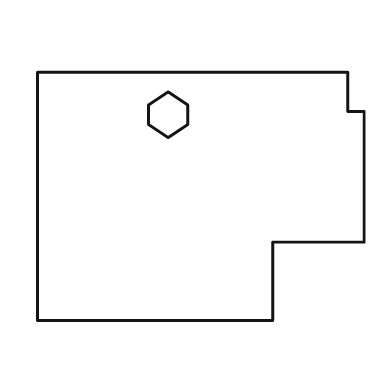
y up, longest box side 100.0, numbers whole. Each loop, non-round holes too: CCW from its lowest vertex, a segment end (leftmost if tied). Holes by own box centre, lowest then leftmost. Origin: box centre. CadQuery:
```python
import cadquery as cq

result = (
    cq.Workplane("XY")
    .moveTo(-50.0, -38.0)
    .lineTo(22.0, -38.0)
    .lineTo(22.0, -14.0)
    .lineTo(50.0, -14.0)
    .lineTo(50.0, 26.0)
    .lineTo(45.0, 26.0)
    .lineTo(45.0, 38.0)
    .lineTo(-50.0, 38.0)
    .close()
    .moveTo(-10.0, 18.0)
    .lineTo(-4.0, 22.0)
    .lineTo(-4.0, 28.0)
    .lineTo(-10.0, 32.0)
    .lineTo(-16.0, 28.0)
    .lineTo(-16.0, 22.0)
    .close()
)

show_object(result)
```